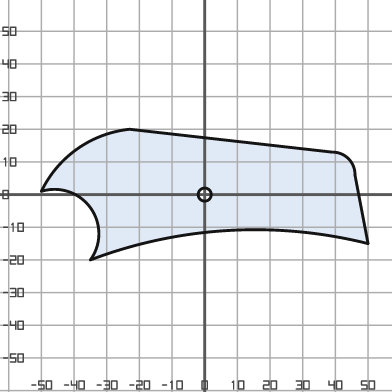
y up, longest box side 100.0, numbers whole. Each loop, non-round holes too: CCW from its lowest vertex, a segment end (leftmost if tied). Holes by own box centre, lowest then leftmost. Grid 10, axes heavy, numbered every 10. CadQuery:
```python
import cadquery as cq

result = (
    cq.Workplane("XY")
    .moveTo(-35.0, -20.0)
    .threePointArc((7.0, -11.0), (50.0, -15.0))
    .lineTo(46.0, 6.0)
    .threePointArc((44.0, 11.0), (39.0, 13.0))
    .lineTo(-23.0, 20.0)
    .threePointArc((-39.0, 14.0), (-50.0, 1.0))
    .threePointArc((-35.0, -4.0), (-35.0, -20.0))
    .close()
    .moveTo(0.0, 0.0)
    .circle(2.0)
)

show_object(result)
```